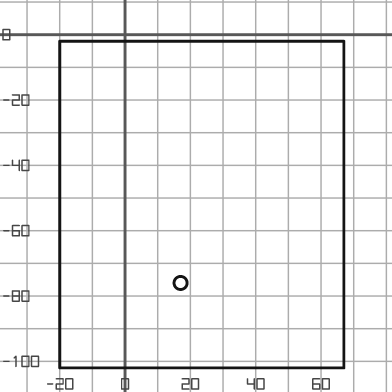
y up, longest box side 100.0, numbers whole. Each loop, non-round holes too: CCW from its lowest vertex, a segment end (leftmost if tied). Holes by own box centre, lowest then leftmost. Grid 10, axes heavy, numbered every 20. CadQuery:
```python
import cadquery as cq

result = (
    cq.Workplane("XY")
    .moveTo(-20.0, -102.0)
    .lineTo(67.0, -102.0)
    .lineTo(67.0, -2.0)
    .lineTo(-20.0, -2.0)
    .close()
    .moveTo(17.0, -76.0)
    .circle(2.0)
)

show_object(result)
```